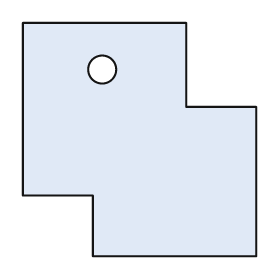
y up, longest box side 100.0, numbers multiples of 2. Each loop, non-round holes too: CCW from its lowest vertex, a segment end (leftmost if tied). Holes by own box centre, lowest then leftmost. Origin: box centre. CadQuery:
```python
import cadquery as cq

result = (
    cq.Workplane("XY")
    .moveTo(-20.0, -50.0)
    .lineTo(50.0, -50.0)
    .lineTo(50.0, 14.0)
    .lineTo(20.0, 14.0)
    .lineTo(20.0, 50.0)
    .lineTo(-50.0, 50.0)
    .lineTo(-50.0, -24.0)
    .lineTo(-20.0, -24.0)
    .close()
    .moveTo(-16.0, 30.0)
    .circle(6.0)
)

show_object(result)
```